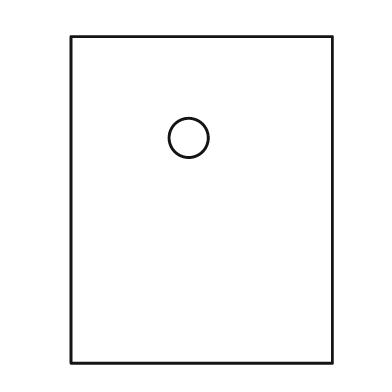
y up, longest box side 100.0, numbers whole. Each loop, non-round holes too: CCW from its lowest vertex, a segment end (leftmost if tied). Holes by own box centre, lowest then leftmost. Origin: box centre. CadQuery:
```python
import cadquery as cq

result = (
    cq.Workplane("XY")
    .moveTo(-40.0, -50.0)
    .lineTo(40.0, -50.0)
    .lineTo(40.0, 50.0)
    .lineTo(-40.0, 50.0)
    .close()
    .moveTo(-4.0, 19.0)
    .circle(6.0)
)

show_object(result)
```